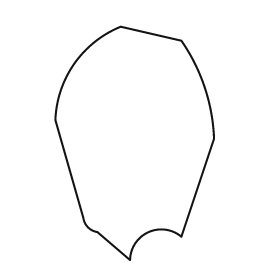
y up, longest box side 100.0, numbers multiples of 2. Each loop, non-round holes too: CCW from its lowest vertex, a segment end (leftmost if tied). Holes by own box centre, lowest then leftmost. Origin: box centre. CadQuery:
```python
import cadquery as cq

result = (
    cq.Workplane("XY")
    .moveTo(-2.0, -50.0)
    .threePointArc((6.0, -38.0), (20.0, -40.0))
    .lineTo(34.0, 2.0)
    .threePointArc((30.0, 24.0), (20.0, 44.0))
    .lineTo(-6.0, 50.0)
    .threePointArc((-26.0, 34.0), (-34.0, 10.0))
    .lineTo(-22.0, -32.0)
    .threePointArc((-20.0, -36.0), (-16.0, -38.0))
    .close()
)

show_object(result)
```